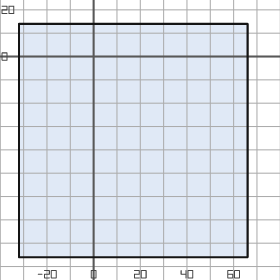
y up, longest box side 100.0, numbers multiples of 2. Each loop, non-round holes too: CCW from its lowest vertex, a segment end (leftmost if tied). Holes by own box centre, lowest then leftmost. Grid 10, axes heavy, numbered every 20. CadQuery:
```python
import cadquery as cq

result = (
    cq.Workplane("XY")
    .moveTo(-32.0, -86.0)
    .lineTo(66.0, -86.0)
    .lineTo(66.0, 14.0)
    .lineTo(-32.0, 14.0)
    .close()
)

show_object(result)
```